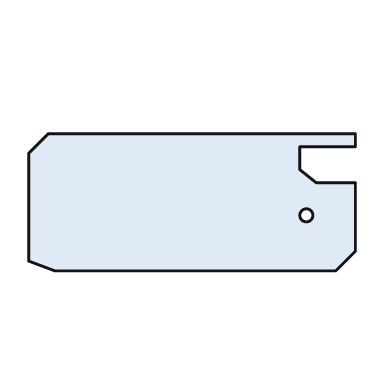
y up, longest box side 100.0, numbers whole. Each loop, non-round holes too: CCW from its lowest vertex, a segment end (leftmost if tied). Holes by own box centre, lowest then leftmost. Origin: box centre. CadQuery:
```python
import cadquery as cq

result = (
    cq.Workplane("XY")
    .moveTo(-42.0, -21.0)
    .lineTo(44.0, -21.0)
    .lineTo(50.0, -15.0)
    .lineTo(50.0, 6.0)
    .lineTo(38.0, 6.0)
    .lineTo(33.0, 10.0)
    .lineTo(33.0, 17.0)
    .lineTo(50.0, 17.0)
    .lineTo(50.0, 21.0)
    .lineTo(-44.0, 21.0)
    .lineTo(-50.0, 15.0)
    .lineTo(-50.0, -18.0)
    .close()
    .moveTo(35.0, -4.0)
    .circle(2.0)
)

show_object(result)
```